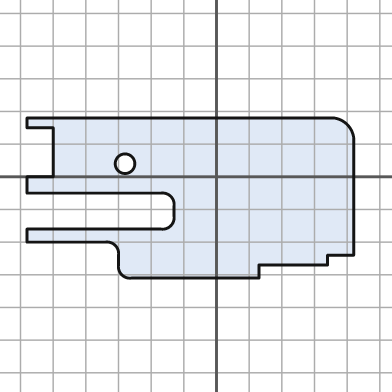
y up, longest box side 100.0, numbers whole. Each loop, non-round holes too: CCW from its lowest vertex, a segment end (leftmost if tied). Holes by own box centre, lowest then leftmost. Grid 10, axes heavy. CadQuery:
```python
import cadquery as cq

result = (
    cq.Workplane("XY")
    .moveTo(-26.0, -31.0)
    .lineTo(13.0, -31.0)
    .lineTo(13.0, -27.0)
    .lineTo(34.0, -27.0)
    .lineTo(34.0, -24.0)
    .lineTo(42.0, -24.0)
    .lineTo(42.0, 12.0)
    .threePointArc((40.0, 16.0), (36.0, 18.0))
    .lineTo(-58.0, 18.0)
    .lineTo(-58.0, 15.0)
    .lineTo(-50.0, 15.0)
    .lineTo(-50.0, 0.0)
    .lineTo(-58.0, 0.0)
    .lineTo(-58.0, -5.0)
    .lineTo(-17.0, -5.0)
    .threePointArc((-14.0, -6.0), (-13.0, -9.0))
    .lineTo(-13.0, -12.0)
    .threePointArc((-14.0, -15.0), (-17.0, -16.0))
    .lineTo(-58.0, -16.0)
    .lineTo(-58.0, -20.0)
    .lineTo(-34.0, -20.0)
    .threePointArc((-31.0, -21.0), (-30.0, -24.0))
    .lineTo(-30.0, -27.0)
    .threePointArc((-29.0, -30.0), (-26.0, -31.0))
    .close()
    .moveTo(-28.0, 4.0)
    .circle(3.0)
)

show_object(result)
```